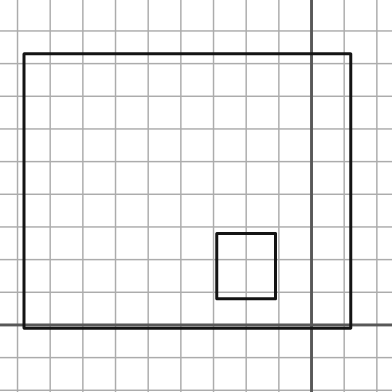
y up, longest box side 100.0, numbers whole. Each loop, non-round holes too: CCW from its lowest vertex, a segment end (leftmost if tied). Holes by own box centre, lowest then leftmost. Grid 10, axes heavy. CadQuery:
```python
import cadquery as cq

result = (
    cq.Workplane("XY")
    .moveTo(-88.0, -1.0)
    .lineTo(12.0, -1.0)
    .lineTo(12.0, 83.0)
    .lineTo(-88.0, 83.0)
    .close()
    .moveTo(-29.0, 8.0)
    .lineTo(-11.0, 8.0)
    .lineTo(-11.0, 28.0)
    .lineTo(-29.0, 28.0)
    .close()
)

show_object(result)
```